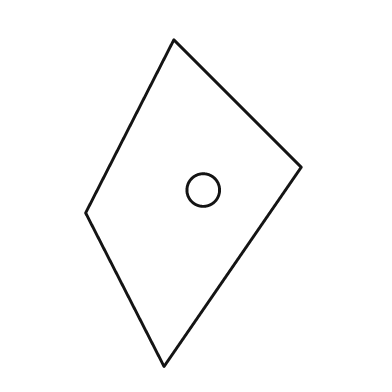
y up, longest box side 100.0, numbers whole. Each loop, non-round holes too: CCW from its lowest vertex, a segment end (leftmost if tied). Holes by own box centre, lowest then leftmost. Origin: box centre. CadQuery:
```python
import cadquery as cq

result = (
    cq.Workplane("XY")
    .moveTo(-9.0, -50.0)
    .lineTo(33.0, 11.0)
    .lineTo(-6.0, 50.0)
    .lineTo(-33.0, -3.0)
    .close()
    .moveTo(3.0, 4.0)
    .circle(5.0)
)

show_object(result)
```